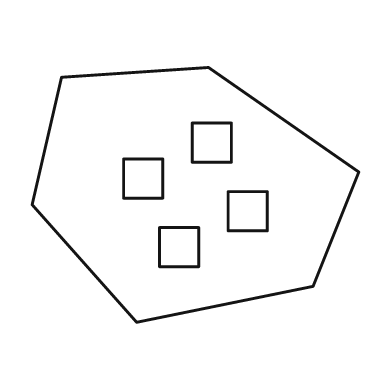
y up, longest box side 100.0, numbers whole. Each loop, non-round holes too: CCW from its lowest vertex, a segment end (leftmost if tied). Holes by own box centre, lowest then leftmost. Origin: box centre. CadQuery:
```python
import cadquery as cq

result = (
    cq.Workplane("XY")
    .moveTo(-18.0, -39.0)
    .lineTo(36.0, -28.0)
    .lineTo(50.0, 7.0)
    .lineTo(4.0, 39.0)
    .lineTo(-41.0, 36.0)
    .lineTo(-50.0, -3.0)
    .close()
    .moveTo(-11.0, -22.0)
    .lineTo(1.0, -22.0)
    .lineTo(1.0, -10.0)
    .lineTo(-11.0, -10.0)
    .close()
    .moveTo(10.0, -11.0)
    .lineTo(22.0, -11.0)
    .lineTo(22.0, 1.0)
    .lineTo(10.0, 1.0)
    .close()
    .moveTo(-22.0, -1.0)
    .lineTo(-10.0, -1.0)
    .lineTo(-10.0, 11.0)
    .lineTo(-22.0, 11.0)
    .close()
    .moveTo(-1.0, 10.0)
    .lineTo(11.0, 10.0)
    .lineTo(11.0, 22.0)
    .lineTo(-1.0, 22.0)
    .close()
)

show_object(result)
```